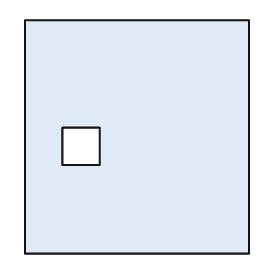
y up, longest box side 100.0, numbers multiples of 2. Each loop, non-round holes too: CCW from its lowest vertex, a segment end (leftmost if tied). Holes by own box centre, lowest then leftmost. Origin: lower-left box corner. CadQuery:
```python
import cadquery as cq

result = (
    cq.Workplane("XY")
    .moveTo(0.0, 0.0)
    .lineTo(96.0, 0.0)
    .lineTo(96.0, 100.0)
    .lineTo(0.0, 100.0)
    .close()
    .moveTo(16.0, 38.0)
    .lineTo(32.0, 38.0)
    .lineTo(32.0, 54.0)
    .lineTo(16.0, 54.0)
    .close()
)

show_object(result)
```